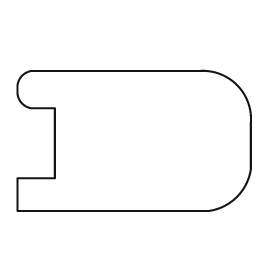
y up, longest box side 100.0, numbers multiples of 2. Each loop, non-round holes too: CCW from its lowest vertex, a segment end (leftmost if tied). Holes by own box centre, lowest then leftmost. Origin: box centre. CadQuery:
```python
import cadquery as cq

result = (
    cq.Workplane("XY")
    .moveTo(-50.0, -30.0)
    .lineTo(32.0, -30.0)
    .threePointArc((44.0, -24.0), (50.0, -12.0))
    .lineTo(50.0, 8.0)
    .threePointArc((44.0, 24.0), (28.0, 30.0))
    .lineTo(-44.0, 30.0)
    .threePointArc((-48.0, 28.0), (-50.0, 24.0))
    .lineTo(-50.0, 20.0)
    .threePointArc((-48.0, 16.0), (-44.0, 14.0))
    .lineTo(-34.0, 14.0)
    .lineTo(-34.0, -16.0)
    .lineTo(-50.0, -16.0)
    .close()
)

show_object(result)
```